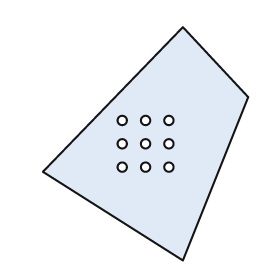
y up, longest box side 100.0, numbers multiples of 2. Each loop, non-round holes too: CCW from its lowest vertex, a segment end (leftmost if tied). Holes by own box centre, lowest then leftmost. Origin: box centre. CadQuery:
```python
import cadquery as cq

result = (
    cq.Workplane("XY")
    .moveTo(16.0, -50.0)
    .lineTo(44.0, 20.0)
    .lineTo(16.0, 50.0)
    .lineTo(-44.0, -12.0)
    .close()
    .moveTo(-10.0, -10.0)
    .circle(2.0)
    .moveTo(0.0, -10.0)
    .circle(2.0)
    .moveTo(10.0, -10.0)
    .circle(2.0)
    .moveTo(-10.0, 0.0)
    .circle(2.0)
    .moveTo(0.0, 0.0)
    .circle(2.0)
    .moveTo(10.0, 0.0)
    .circle(2.0)
    .moveTo(-10.0, 10.0)
    .circle(2.0)
    .moveTo(0.0, 10.0)
    .circle(2.0)
    .moveTo(10.0, 10.0)
    .circle(2.0)
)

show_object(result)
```